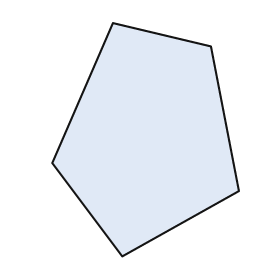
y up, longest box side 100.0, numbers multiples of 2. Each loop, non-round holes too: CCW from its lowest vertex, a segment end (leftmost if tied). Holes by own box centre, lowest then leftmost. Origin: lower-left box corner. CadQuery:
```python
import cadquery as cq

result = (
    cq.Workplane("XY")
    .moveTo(30.0, 0.0)
    .lineTo(80.0, 28.0)
    .lineTo(68.0, 90.0)
    .lineTo(26.0, 100.0)
    .lineTo(0.0, 40.0)
    .close()
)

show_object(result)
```